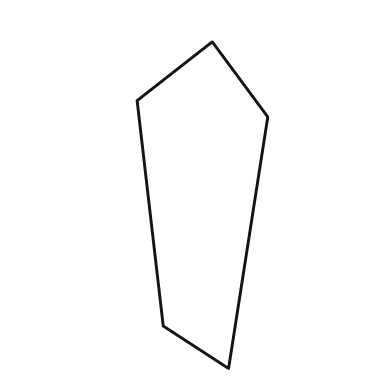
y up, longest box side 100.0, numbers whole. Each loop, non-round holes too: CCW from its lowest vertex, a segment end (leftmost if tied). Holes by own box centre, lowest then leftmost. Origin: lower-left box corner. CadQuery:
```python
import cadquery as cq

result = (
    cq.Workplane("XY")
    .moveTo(28.0, 0.0)
    .lineTo(40.0, 77.0)
    .lineTo(23.0, 100.0)
    .lineTo(0.0, 82.0)
    .lineTo(8.0, 13.0)
    .close()
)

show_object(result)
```